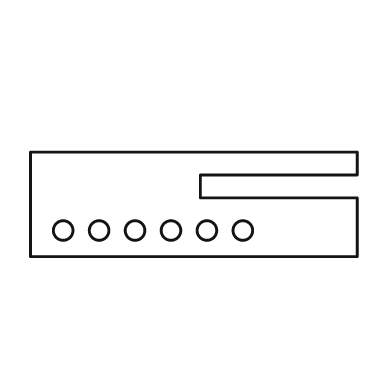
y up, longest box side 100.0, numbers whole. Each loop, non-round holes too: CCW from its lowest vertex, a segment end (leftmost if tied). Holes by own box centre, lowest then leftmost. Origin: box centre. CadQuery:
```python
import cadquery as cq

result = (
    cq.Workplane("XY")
    .moveTo(-50.0, -16.0)
    .lineTo(50.0, -16.0)
    .lineTo(50.0, 2.0)
    .lineTo(2.0, 2.0)
    .lineTo(2.0, 9.0)
    .lineTo(50.0, 9.0)
    .lineTo(50.0, 16.0)
    .lineTo(-50.0, 16.0)
    .close()
    .moveTo(-40.0, -8.0)
    .circle(3.0)
    .moveTo(-29.0, -8.0)
    .circle(3.0)
    .moveTo(-18.0, -8.0)
    .circle(3.0)
    .moveTo(-7.0, -8.0)
    .circle(3.0)
    .moveTo(4.0, -8.0)
    .circle(3.0)
    .moveTo(15.0, -8.0)
    .circle(3.0)
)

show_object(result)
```